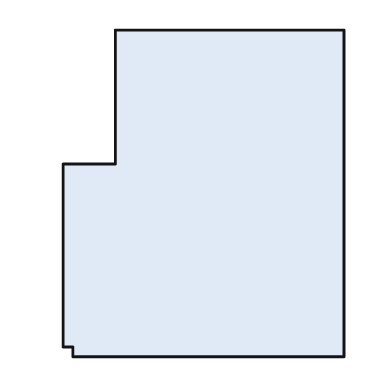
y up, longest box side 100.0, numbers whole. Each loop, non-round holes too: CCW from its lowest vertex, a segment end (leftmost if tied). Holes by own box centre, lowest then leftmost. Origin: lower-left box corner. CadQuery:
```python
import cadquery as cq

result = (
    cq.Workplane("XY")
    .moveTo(3.0, 0.0)
    .lineTo(86.0, 0.0)
    .lineTo(86.0, 100.0)
    .lineTo(16.0, 100.0)
    .lineTo(16.0, 59.0)
    .lineTo(0.0, 59.0)
    .lineTo(0.0, 3.0)
    .lineTo(3.0, 3.0)
    .close()
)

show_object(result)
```